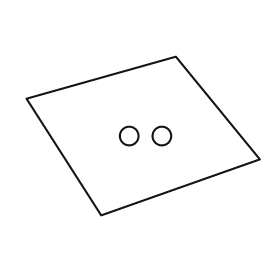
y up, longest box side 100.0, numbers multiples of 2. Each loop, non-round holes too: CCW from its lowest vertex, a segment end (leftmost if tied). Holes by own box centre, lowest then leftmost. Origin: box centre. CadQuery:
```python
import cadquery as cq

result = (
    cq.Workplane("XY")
    .moveTo(-18.0, -34.0)
    .lineTo(50.0, -10.0)
    .lineTo(14.0, 34.0)
    .lineTo(-50.0, 16.0)
    .close()
    .moveTo(-6.0, 0.0)
    .circle(4.0)
    .moveTo(8.0, 0.0)
    .circle(4.0)
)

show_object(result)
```